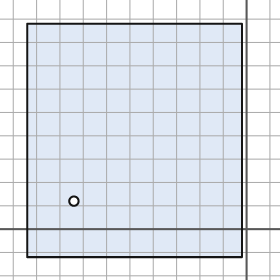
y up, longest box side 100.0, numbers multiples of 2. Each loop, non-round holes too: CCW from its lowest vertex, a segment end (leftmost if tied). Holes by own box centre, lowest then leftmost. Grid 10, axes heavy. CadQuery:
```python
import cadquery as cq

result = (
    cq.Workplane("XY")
    .moveTo(-94.0, -12.0)
    .lineTo(-2.0, -12.0)
    .lineTo(-2.0, 88.0)
    .lineTo(-94.0, 88.0)
    .close()
    .moveTo(-74.0, 12.0)
    .circle(2.0)
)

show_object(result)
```